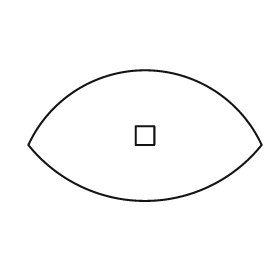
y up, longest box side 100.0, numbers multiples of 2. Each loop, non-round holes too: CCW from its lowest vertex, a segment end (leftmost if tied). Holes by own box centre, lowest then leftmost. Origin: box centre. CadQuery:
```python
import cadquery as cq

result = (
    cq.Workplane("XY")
    .moveTo(-50.0, -4.0)
    .threePointArc((0.0, -28.0), (50.0, -4.0))
    .threePointArc((0.0, 28.0), (-50.0, -4.0))
    .close()
    .moveTo(-4.0, -4.0)
    .lineTo(4.0, -4.0)
    .lineTo(4.0, 4.0)
    .lineTo(-4.0, 4.0)
    .close()
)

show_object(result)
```